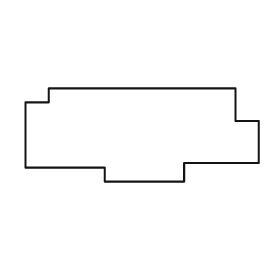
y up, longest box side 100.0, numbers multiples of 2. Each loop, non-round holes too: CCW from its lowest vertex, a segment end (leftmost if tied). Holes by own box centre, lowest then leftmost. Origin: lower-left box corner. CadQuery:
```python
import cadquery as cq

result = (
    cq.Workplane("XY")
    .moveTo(34.0, 0.0)
    .lineTo(68.0, 0.0)
    .lineTo(68.0, 8.0)
    .lineTo(100.0, 8.0)
    .lineTo(100.0, 26.0)
    .lineTo(90.0, 26.0)
    .lineTo(90.0, 40.0)
    .lineTo(10.0, 40.0)
    .lineTo(10.0, 34.0)
    .lineTo(0.0, 34.0)
    .lineTo(0.0, 6.0)
    .lineTo(34.0, 6.0)
    .close()
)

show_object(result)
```